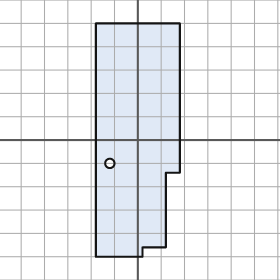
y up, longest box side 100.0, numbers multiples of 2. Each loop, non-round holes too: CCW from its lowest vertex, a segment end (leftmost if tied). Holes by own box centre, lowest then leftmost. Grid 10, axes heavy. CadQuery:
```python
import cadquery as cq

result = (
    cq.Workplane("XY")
    .moveTo(-18.0, -50.0)
    .lineTo(2.0, -50.0)
    .lineTo(2.0, -46.0)
    .lineTo(12.0, -46.0)
    .lineTo(12.0, -14.0)
    .lineTo(18.0, -14.0)
    .lineTo(18.0, 50.0)
    .lineTo(-18.0, 50.0)
    .close()
    .moveTo(-12.0, -10.0)
    .circle(2.0)
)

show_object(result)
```